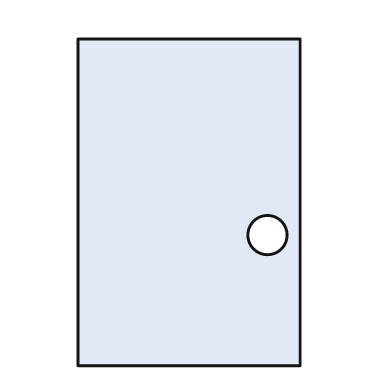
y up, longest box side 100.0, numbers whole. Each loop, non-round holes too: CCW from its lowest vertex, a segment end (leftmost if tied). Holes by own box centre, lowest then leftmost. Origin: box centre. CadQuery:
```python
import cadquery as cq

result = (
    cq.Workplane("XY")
    .moveTo(-34.0, -50.0)
    .lineTo(34.0, -50.0)
    .lineTo(34.0, 50.0)
    .lineTo(-34.0, 50.0)
    .close()
    .moveTo(24.0, -10.0)
    .circle(6.0)
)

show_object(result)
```